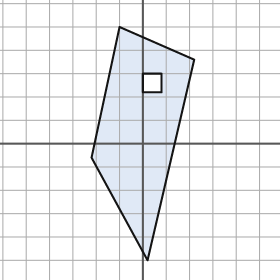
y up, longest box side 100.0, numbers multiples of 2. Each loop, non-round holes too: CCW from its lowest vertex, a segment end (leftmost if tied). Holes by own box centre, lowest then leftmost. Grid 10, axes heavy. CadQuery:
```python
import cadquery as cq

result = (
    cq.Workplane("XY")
    .moveTo(2.0, -50.0)
    .lineTo(22.0, 36.0)
    .lineTo(-10.0, 50.0)
    .lineTo(-22.0, -6.0)
    .close()
    .moveTo(0.0, 22.0)
    .lineTo(8.0, 22.0)
    .lineTo(8.0, 30.0)
    .lineTo(0.0, 30.0)
    .close()
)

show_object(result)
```